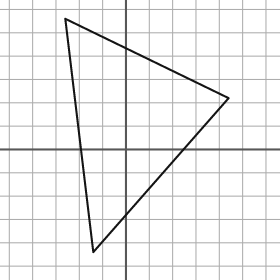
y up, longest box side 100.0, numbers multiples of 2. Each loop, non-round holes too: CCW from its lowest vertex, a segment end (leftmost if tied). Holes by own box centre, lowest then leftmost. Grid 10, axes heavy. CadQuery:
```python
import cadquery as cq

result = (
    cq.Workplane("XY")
    .moveTo(-14.0, -44.0)
    .lineTo(44.0, 22.0)
    .lineTo(-26.0, 56.0)
    .close()
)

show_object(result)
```